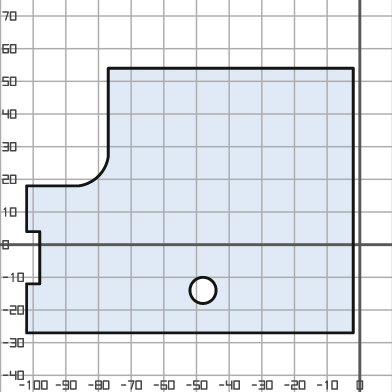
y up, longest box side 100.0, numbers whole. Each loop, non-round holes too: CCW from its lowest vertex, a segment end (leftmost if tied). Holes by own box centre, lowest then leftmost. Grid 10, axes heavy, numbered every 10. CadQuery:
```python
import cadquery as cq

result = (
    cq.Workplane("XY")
    .moveTo(-102.0, -27.0)
    .lineTo(-2.0, -27.0)
    .lineTo(-2.0, 54.0)
    .lineTo(-77.0, 54.0)
    .lineTo(-77.0, 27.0)
    .threePointArc((-80.0, 21.0), (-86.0, 18.0))
    .lineTo(-102.0, 18.0)
    .lineTo(-102.0, 4.0)
    .lineTo(-98.0, 4.0)
    .lineTo(-98.0, -12.0)
    .lineTo(-102.0, -12.0)
    .close()
    .moveTo(-48.0, -14.0)
    .circle(4.0)
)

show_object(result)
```